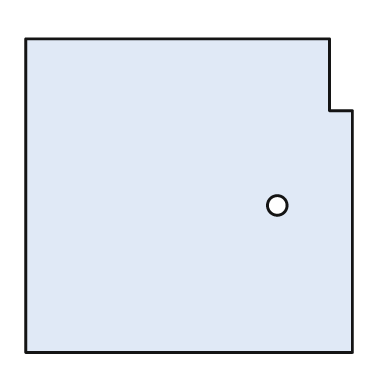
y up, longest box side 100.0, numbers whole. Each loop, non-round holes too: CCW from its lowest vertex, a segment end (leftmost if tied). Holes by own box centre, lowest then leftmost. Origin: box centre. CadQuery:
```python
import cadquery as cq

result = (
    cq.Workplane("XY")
    .moveTo(-50.0, -48.0)
    .lineTo(50.0, -48.0)
    .lineTo(50.0, 26.0)
    .lineTo(43.0, 26.0)
    .lineTo(43.0, 48.0)
    .lineTo(-50.0, 48.0)
    .close()
    .moveTo(27.0, -3.0)
    .circle(3.0)
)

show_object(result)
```